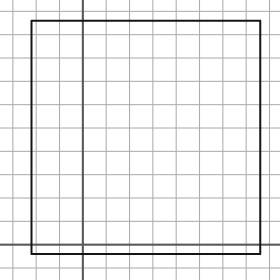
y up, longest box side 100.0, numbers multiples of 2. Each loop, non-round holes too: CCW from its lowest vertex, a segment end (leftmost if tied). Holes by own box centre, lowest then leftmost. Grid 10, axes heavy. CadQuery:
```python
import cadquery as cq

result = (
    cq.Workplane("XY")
    .moveTo(-22.0, -4.0)
    .lineTo(76.0, -4.0)
    .lineTo(76.0, 96.0)
    .lineTo(-22.0, 96.0)
    .close()
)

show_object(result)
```